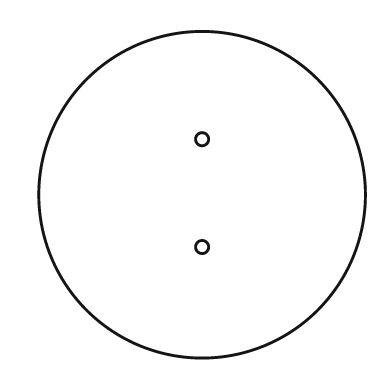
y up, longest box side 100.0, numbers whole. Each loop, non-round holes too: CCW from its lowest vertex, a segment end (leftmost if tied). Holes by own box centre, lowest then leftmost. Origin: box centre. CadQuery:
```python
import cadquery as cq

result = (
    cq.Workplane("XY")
    .moveTo(0.0, 0.0)
    .circle(50.0)
    .moveTo(0.0, -16.0)
    .circle(2.0)
    .moveTo(0.0, 17.0)
    .circle(2.0)
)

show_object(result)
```